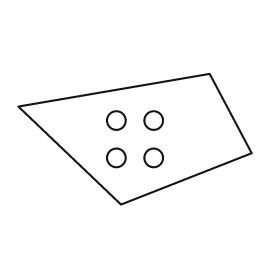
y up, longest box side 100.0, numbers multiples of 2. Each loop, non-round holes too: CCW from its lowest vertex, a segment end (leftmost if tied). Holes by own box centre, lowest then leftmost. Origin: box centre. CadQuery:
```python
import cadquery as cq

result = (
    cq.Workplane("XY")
    .moveTo(-6.0, -28.0)
    .lineTo(50.0, -6.0)
    .lineTo(32.0, 28.0)
    .lineTo(-50.0, 14.0)
    .close()
    .moveTo(-8.0, -8.0)
    .circle(4.0)
    .moveTo(8.0, -8.0)
    .circle(4.0)
    .moveTo(-8.0, 8.0)
    .circle(4.0)
    .moveTo(8.0, 8.0)
    .circle(4.0)
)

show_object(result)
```